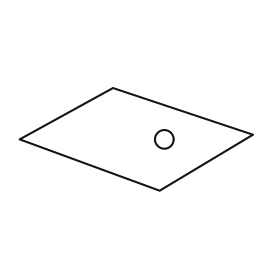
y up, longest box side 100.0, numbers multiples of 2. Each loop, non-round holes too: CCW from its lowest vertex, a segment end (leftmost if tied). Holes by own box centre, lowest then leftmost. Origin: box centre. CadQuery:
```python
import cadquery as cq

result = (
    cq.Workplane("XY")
    .moveTo(10.0, -22.0)
    .lineTo(50.0, 2.0)
    .lineTo(-10.0, 22.0)
    .lineTo(-50.0, 0.0)
    .close()
    .moveTo(12.0, 0.0)
    .circle(4.0)
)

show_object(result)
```